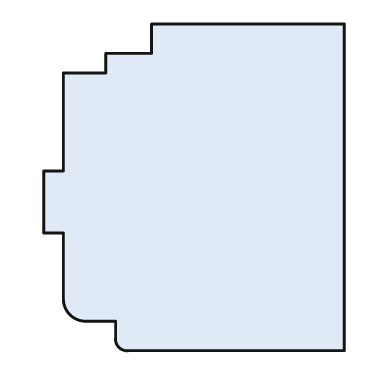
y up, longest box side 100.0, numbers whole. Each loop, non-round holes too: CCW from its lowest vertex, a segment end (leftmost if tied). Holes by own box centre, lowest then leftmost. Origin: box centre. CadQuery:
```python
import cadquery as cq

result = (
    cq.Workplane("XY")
    .moveTo(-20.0, -50.0)
    .lineTo(46.0, -50.0)
    .lineTo(46.0, 50.0)
    .lineTo(-13.0, 50.0)
    .lineTo(-13.0, 41.0)
    .lineTo(-27.0, 41.0)
    .lineTo(-27.0, 35.0)
    .lineTo(-40.0, 35.0)
    .lineTo(-40.0, 5.0)
    .lineTo(-46.0, 5.0)
    .lineTo(-46.0, -14.0)
    .lineTo(-40.0, -14.0)
    .lineTo(-40.0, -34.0)
    .threePointArc((-38.0, -39.0), (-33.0, -41.0))
    .lineTo(-24.0, -41.0)
    .lineTo(-24.0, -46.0)
    .threePointArc((-23.0, -49.0), (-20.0, -50.0))
    .close()
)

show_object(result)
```